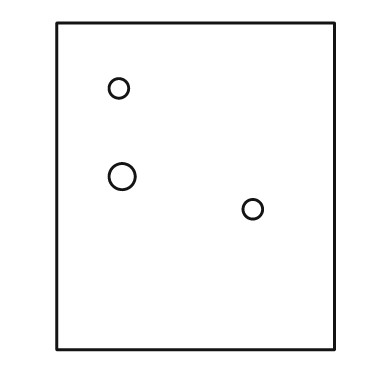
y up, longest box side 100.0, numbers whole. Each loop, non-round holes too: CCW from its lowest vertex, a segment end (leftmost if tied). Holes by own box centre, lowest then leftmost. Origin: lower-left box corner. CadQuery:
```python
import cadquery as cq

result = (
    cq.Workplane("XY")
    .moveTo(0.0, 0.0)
    .lineTo(85.0, 0.0)
    .lineTo(85.0, 100.0)
    .lineTo(0.0, 100.0)
    .close()
    .moveTo(60.0, 43.0)
    .circle(3.0)
    .moveTo(20.0, 53.0)
    .circle(4.0)
    .moveTo(19.0, 80.0)
    .circle(3.0)
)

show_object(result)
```